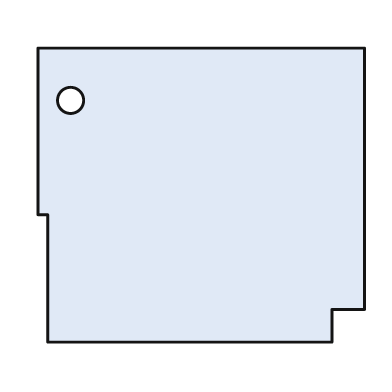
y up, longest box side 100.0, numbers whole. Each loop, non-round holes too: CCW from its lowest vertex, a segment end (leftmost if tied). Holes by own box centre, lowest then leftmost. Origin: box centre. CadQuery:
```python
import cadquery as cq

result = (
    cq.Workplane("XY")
    .moveTo(-47.0, -45.0)
    .lineTo(40.0, -45.0)
    .lineTo(40.0, -35.0)
    .lineTo(50.0, -35.0)
    .lineTo(50.0, 45.0)
    .lineTo(-50.0, 45.0)
    .lineTo(-50.0, -6.0)
    .lineTo(-47.0, -6.0)
    .close()
    .moveTo(-40.0, 29.0)
    .circle(4.0)
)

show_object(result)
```